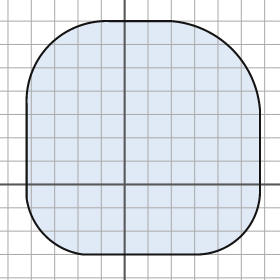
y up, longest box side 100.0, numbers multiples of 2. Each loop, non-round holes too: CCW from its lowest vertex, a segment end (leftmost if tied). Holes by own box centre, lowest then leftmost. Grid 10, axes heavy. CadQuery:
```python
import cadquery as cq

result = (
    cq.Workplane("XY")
    .moveTo(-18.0, -30.0)
    .lineTo(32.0, -30.0)
    .threePointArc((50.0, -22.0), (58.0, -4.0))
    .lineTo(58.0, 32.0)
    .threePointArc((46.0, 58.0), (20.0, 70.0))
    .lineTo(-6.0, 70.0)
    .threePointArc((-32.0, 60.0), (-42.0, 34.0))
    .lineTo(-42.0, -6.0)
    .threePointArc((-34.0, -22.0), (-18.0, -30.0))
    .close()
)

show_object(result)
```